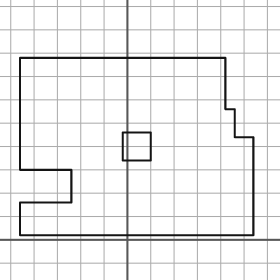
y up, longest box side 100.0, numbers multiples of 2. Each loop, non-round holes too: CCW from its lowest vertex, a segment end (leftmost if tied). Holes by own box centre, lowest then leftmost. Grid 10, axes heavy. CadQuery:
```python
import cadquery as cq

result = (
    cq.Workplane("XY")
    .moveTo(-46.0, 2.0)
    .lineTo(54.0, 2.0)
    .lineTo(54.0, 44.0)
    .lineTo(46.0, 44.0)
    .lineTo(46.0, 56.0)
    .lineTo(42.0, 56.0)
    .lineTo(42.0, 78.0)
    .lineTo(-46.0, 78.0)
    .lineTo(-46.0, 30.0)
    .lineTo(-24.0, 30.0)
    .lineTo(-24.0, 16.0)
    .lineTo(-46.0, 16.0)
    .close()
    .moveTo(-2.0, 34.0)
    .lineTo(10.0, 34.0)
    .lineTo(10.0, 46.0)
    .lineTo(-2.0, 46.0)
    .close()
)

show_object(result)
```